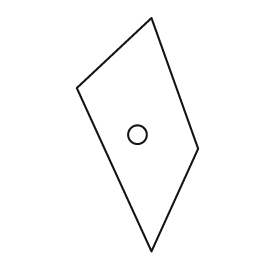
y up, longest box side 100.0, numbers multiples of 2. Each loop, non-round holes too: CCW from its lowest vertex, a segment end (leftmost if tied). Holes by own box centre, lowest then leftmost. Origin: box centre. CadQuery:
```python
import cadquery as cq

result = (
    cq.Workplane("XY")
    .moveTo(6.0, -50.0)
    .lineTo(26.0, -6.0)
    .lineTo(6.0, 50.0)
    .lineTo(-26.0, 20.0)
    .close()
    .moveTo(0.0, 0.0)
    .circle(4.0)
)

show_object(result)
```